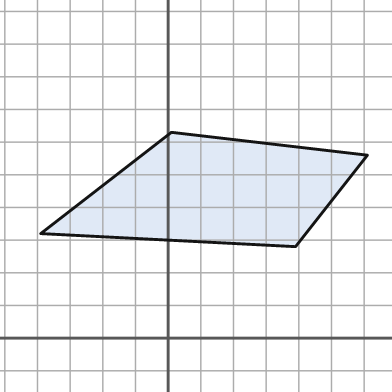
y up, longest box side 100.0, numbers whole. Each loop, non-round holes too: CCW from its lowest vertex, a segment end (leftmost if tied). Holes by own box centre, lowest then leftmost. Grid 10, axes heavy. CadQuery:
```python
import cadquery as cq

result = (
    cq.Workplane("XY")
    .moveTo(39.0, 28.0)
    .lineTo(61.0, 56.0)
    .lineTo(1.0, 63.0)
    .lineTo(-39.0, 32.0)
    .close()
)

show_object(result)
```